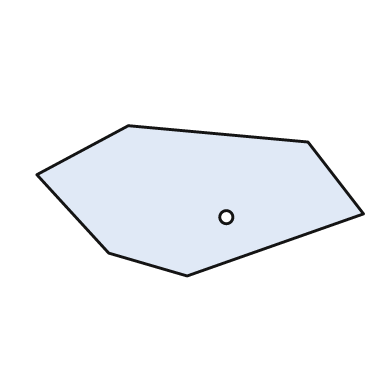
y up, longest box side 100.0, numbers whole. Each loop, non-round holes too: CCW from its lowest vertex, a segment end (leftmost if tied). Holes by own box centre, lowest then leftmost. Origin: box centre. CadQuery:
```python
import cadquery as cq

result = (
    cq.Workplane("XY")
    .moveTo(-4.0, -23.0)
    .lineTo(50.0, -4.0)
    .lineTo(33.0, 18.0)
    .lineTo(-22.0, 23.0)
    .lineTo(-50.0, 8.0)
    .lineTo(-28.0, -16.0)
    .close()
    .moveTo(8.0, -5.0)
    .circle(2.0)
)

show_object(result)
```